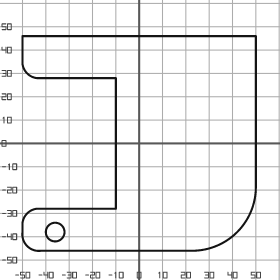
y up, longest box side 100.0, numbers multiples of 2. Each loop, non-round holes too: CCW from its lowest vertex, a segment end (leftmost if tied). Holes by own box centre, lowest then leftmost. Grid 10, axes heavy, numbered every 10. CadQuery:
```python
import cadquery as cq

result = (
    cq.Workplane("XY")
    .moveTo(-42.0, -46.0)
    .lineTo(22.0, -46.0)
    .threePointArc((42.0, -38.0), (50.0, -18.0))
    .lineTo(50.0, 46.0)
    .lineTo(-50.0, 46.0)
    .lineTo(-50.0, 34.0)
    .threePointArc((-48.0, 30.0), (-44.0, 28.0))
    .lineTo(-10.0, 28.0)
    .lineTo(-10.0, -28.0)
    .lineTo(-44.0, -28.0)
    .threePointArc((-48.0, -30.0), (-50.0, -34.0))
    .lineTo(-50.0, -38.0)
    .threePointArc((-48.0, -44.0), (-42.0, -46.0))
    .close()
    .moveTo(-36.0, -38.0)
    .circle(4.0)
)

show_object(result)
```